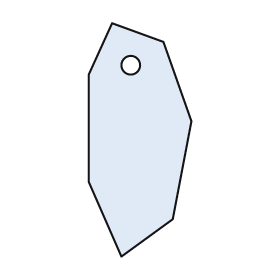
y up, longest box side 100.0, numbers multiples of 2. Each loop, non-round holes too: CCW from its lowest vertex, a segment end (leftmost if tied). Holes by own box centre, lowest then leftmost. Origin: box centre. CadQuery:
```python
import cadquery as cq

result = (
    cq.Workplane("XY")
    .moveTo(-8.0, -50.0)
    .lineTo(14.0, -34.0)
    .lineTo(22.0, 8.0)
    .lineTo(10.0, 42.0)
    .lineTo(-12.0, 50.0)
    .lineTo(-22.0, 28.0)
    .lineTo(-22.0, -18.0)
    .close()
    .moveTo(-4.0, 32.0)
    .circle(4.0)
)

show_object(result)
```